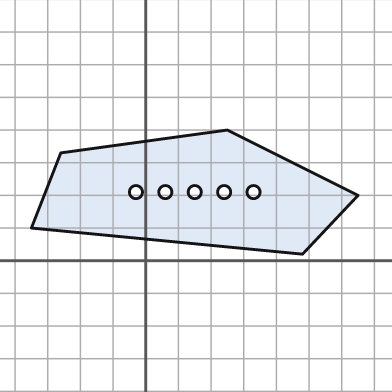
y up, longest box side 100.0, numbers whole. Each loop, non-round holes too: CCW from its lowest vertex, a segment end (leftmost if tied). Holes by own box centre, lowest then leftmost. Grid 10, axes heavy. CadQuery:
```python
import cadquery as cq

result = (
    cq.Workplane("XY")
    .moveTo(48.0, 2.0)
    .lineTo(65.0, 20.0)
    .lineTo(25.0, 40.0)
    .lineTo(-26.0, 33.0)
    .lineTo(-35.0, 10.0)
    .close()
    .moveTo(-3.0, 21.0)
    .circle(2.0)
    .moveTo(6.0, 21.0)
    .circle(2.0)
    .moveTo(15.0, 21.0)
    .circle(2.0)
    .moveTo(24.0, 21.0)
    .circle(2.0)
    .moveTo(33.0, 21.0)
    .circle(2.0)
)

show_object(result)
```